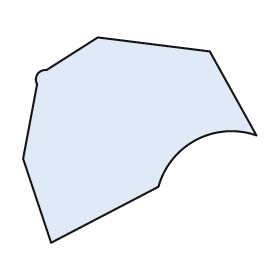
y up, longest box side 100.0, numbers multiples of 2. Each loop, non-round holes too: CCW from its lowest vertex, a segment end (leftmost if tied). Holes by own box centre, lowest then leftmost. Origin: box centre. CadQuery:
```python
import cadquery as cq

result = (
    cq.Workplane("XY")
    .moveTo(-38.0, -44.0)
    .lineTo(8.0, -20.0)
    .threePointArc((24.0, 0.0), (50.0, 2.0))
    .lineTo(30.0, 38.0)
    .lineTo(-18.0, 44.0)
    .lineTo(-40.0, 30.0)
    .threePointArc((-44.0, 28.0), (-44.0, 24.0))
    .lineTo(-50.0, -8.0)
    .close()
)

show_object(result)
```